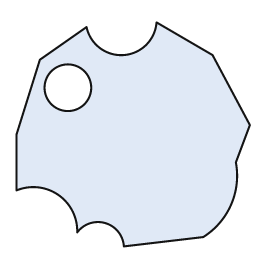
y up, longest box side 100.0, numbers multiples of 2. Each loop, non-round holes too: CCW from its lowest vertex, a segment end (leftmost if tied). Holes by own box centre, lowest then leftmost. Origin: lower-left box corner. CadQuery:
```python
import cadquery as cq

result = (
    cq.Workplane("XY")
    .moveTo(46.0, 0.0)
    .lineTo(80.0, 4.0)
    .threePointArc((92.0, 18.0), (94.0, 36.0))
    .lineTo(100.0, 52.0)
    .lineTo(84.0, 82.0)
    .lineTo(60.0, 96.0)
    .threePointArc((46.0, 82.0), (30.0, 94.0))
    .lineTo(10.0, 80.0)
    .lineTo(0.0, 48.0)
    .lineTo(0.0, 24.0)
    .threePointArc((18.0, 22.0), (26.0, 6.0))
    .threePointArc((38.0, 10.0), (46.0, 0.0))
    .close()
    .moveTo(22.0, 68.0)
    .circle(10.0)
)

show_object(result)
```